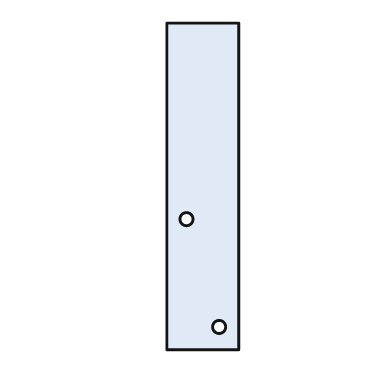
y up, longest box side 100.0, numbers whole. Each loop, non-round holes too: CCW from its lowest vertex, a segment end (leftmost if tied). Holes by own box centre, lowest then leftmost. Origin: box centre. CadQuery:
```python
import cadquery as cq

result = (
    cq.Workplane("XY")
    .moveTo(-11.0, -50.0)
    .lineTo(11.0, -50.0)
    .lineTo(11.0, 50.0)
    .lineTo(-11.0, 50.0)
    .close()
    .moveTo(5.0, -43.0)
    .circle(2.0)
    .moveTo(-5.0, -10.0)
    .circle(2.0)
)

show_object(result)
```